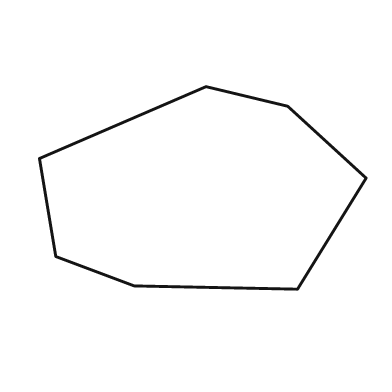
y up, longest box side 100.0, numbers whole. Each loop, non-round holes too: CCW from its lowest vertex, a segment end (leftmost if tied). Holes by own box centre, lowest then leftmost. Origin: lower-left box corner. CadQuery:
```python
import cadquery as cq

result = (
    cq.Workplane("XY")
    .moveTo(79.0, 0.0)
    .lineTo(100.0, 34.0)
    .lineTo(76.0, 56.0)
    .lineTo(51.0, 62.0)
    .lineTo(0.0, 40.0)
    .lineTo(5.0, 10.0)
    .lineTo(29.0, 1.0)
    .close()
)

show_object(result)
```